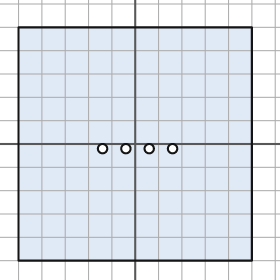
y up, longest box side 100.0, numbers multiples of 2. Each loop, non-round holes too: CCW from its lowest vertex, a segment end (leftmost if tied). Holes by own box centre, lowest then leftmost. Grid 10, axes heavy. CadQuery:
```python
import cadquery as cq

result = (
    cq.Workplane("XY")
    .moveTo(-50.0, -50.0)
    .lineTo(50.0, -50.0)
    .lineTo(50.0, 50.0)
    .lineTo(-50.0, 50.0)
    .close()
    .moveTo(-14.0, -2.0)
    .circle(2.0)
    .moveTo(-4.0, -2.0)
    .circle(2.0)
    .moveTo(6.0, -2.0)
    .circle(2.0)
    .moveTo(16.0, -2.0)
    .circle(2.0)
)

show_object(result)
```